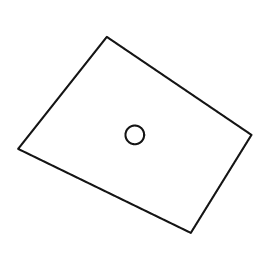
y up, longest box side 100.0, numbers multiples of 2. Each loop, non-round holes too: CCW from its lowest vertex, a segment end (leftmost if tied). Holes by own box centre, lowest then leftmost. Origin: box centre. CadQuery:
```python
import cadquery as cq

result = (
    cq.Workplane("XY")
    .moveTo(24.0, -42.0)
    .lineTo(50.0, 0.0)
    .lineTo(-12.0, 42.0)
    .lineTo(-50.0, -6.0)
    .close()
    .moveTo(0.0, 0.0)
    .circle(4.0)
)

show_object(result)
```